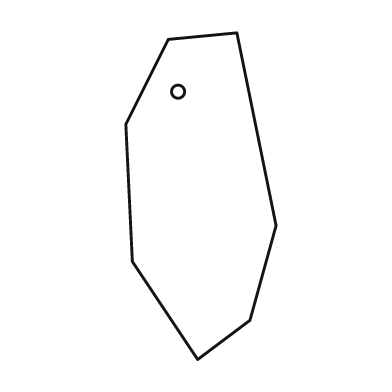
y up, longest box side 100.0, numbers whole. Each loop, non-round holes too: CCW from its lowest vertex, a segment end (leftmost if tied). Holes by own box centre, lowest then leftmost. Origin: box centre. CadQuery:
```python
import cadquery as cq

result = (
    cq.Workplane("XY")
    .moveTo(-1.0, -50.0)
    .lineTo(15.0, -38.0)
    .lineTo(23.0, -9.0)
    .lineTo(11.0, 50.0)
    .lineTo(-10.0, 48.0)
    .lineTo(-23.0, 22.0)
    .lineTo(-21.0, -20.0)
    .close()
    .moveTo(-7.0, 32.0)
    .circle(2.0)
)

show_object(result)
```